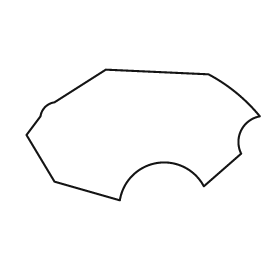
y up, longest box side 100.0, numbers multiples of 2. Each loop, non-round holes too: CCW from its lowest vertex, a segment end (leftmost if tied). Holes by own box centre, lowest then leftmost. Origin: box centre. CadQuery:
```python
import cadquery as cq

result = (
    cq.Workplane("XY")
    .moveTo(-10.0, -28.0)
    .threePointArc((6.0, -12.0), (26.0, -22.0))
    .lineTo(42.0, -8.0)
    .threePointArc((42.0, 2.0), (50.0, 8.0))
    .threePointArc((40.0, 18.0), (28.0, 26.0))
    .lineTo(-16.0, 28.0)
    .lineTo(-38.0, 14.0)
    .threePointArc((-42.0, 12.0), (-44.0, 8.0))
    .lineTo(-50.0, 0.0)
    .lineTo(-38.0, -20.0)
    .close()
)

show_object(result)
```